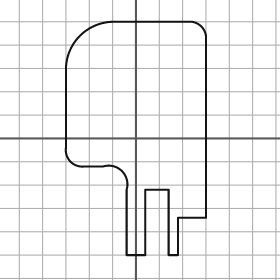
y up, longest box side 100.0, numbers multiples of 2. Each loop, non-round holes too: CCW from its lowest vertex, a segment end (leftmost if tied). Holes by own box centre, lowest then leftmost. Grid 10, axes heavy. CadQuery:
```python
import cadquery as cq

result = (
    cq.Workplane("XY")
    .moveTo(-4.0, -50.0)
    .lineTo(4.0, -50.0)
    .lineTo(4.0, -22.0)
    .lineTo(14.0, -22.0)
    .lineTo(14.0, -50.0)
    .lineTo(18.0, -50.0)
    .lineTo(18.0, -34.0)
    .lineTo(30.0, -34.0)
    .lineTo(30.0, 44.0)
    .threePointArc((28.0, 48.0), (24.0, 50.0))
    .lineTo(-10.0, 50.0)
    .threePointArc((-24.0, 44.0), (-30.0, 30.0))
    .lineTo(-30.0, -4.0)
    .threePointArc((-28.0, -10.0), (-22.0, -12.0))
    .lineTo(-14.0, -12.0)
    .threePointArc((-6.0, -14.0), (-4.0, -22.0))
    .close()
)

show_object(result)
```